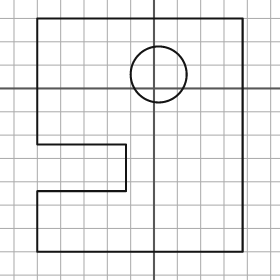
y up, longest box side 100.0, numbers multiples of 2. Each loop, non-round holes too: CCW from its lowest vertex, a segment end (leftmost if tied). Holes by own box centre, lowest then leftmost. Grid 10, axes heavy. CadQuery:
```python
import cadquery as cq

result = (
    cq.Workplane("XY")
    .moveTo(-50.0, -70.0)
    .lineTo(38.0, -70.0)
    .lineTo(38.0, 30.0)
    .lineTo(-50.0, 30.0)
    .lineTo(-50.0, -24.0)
    .lineTo(-12.0, -24.0)
    .lineTo(-12.0, -44.0)
    .lineTo(-50.0, -44.0)
    .close()
    .moveTo(2.0, 6.0)
    .circle(12.0)
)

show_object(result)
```